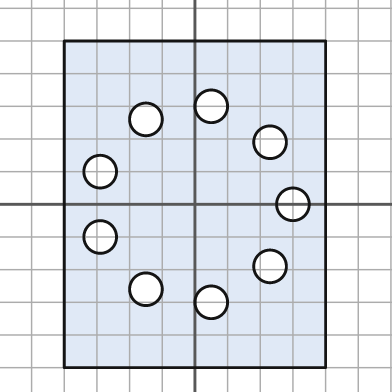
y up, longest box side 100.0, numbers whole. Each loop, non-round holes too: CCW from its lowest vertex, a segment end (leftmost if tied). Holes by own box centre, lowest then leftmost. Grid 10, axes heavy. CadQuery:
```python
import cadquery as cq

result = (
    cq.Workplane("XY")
    .moveTo(-40.0, -50.0)
    .lineTo(40.0, -50.0)
    .lineTo(40.0, 50.0)
    .lineTo(-40.0, 50.0)
    .close()
    .moveTo(5.0, -30.0)
    .circle(5.0)
    .moveTo(-15.0, -26.0)
    .circle(5.0)
    .moveTo(23.0, -19.0)
    .circle(5.0)
    .moveTo(-29.0, -10.0)
    .circle(5.0)
    .moveTo(30.0, 0.0)
    .circle(5.0)
    .moveTo(-29.0, 10.0)
    .circle(5.0)
    .moveTo(23.0, 19.0)
    .circle(5.0)
    .moveTo(-15.0, 26.0)
    .circle(5.0)
    .moveTo(5.0, 30.0)
    .circle(5.0)
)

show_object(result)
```